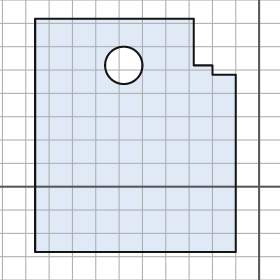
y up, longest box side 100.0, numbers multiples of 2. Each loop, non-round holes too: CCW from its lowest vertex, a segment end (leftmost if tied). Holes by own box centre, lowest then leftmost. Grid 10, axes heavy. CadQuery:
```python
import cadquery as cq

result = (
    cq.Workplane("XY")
    .moveTo(-96.0, -28.0)
    .lineTo(-10.0, -28.0)
    .lineTo(-10.0, 48.0)
    .lineTo(-20.0, 48.0)
    .lineTo(-20.0, 52.0)
    .lineTo(-28.0, 52.0)
    .lineTo(-28.0, 72.0)
    .lineTo(-96.0, 72.0)
    .close()
    .moveTo(-58.0, 52.0)
    .circle(8.0)
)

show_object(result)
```